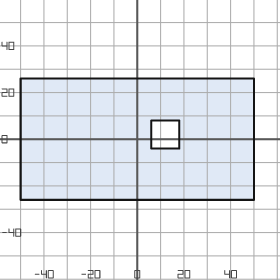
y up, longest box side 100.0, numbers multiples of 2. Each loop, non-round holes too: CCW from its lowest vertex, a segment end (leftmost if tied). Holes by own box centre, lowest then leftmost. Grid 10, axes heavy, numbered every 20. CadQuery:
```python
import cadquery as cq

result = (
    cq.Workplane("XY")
    .moveTo(-50.0, -26.0)
    .lineTo(50.0, -26.0)
    .lineTo(50.0, 26.0)
    .lineTo(-50.0, 26.0)
    .close()
    .moveTo(6.0, -4.0)
    .lineTo(18.0, -4.0)
    .lineTo(18.0, 8.0)
    .lineTo(6.0, 8.0)
    .close()
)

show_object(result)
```